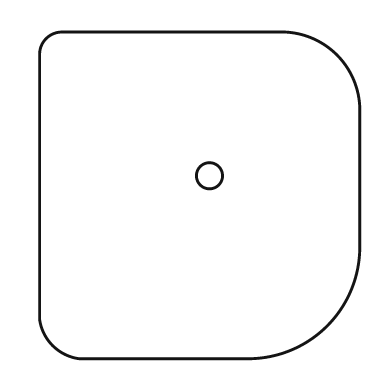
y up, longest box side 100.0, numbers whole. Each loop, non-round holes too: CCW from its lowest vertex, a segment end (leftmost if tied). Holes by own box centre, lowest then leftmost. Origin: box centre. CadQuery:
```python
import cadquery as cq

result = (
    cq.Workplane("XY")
    .moveTo(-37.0, -50.0)
    .lineTo(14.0, -50.0)
    .threePointArc((39.0, -40.0), (49.0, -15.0))
    .lineTo(49.0, 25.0)
    .threePointArc((42.0, 43.0), (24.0, 50.0))
    .lineTo(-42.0, 50.0)
    .threePointArc((-47.0, 48.0), (-49.0, 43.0))
    .lineTo(-49.0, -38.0)
    .threePointArc((-45.0, -46.0), (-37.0, -50.0))
    .close()
    .moveTo(3.0, 6.0)
    .circle(4.0)
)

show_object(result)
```